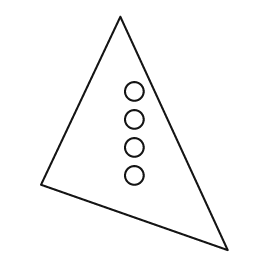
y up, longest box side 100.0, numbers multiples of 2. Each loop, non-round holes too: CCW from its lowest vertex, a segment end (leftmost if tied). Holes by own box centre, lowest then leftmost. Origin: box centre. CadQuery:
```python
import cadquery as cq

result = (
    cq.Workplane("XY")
    .moveTo(40.0, -50.0)
    .lineTo(-6.0, 50.0)
    .lineTo(-40.0, -22.0)
    .close()
    .moveTo(0.0, -18.0)
    .circle(4.0)
    .moveTo(0.0, -6.0)
    .circle(4.0)
    .moveTo(0.0, 6.0)
    .circle(4.0)
    .moveTo(0.0, 18.0)
    .circle(4.0)
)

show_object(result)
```